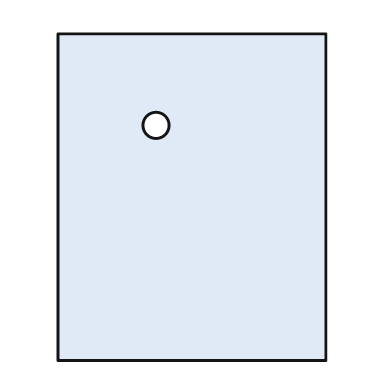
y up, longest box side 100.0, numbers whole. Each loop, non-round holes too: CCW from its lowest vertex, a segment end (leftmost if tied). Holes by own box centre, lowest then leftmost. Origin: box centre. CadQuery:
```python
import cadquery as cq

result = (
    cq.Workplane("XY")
    .moveTo(-41.0, -50.0)
    .lineTo(41.0, -50.0)
    .lineTo(41.0, 50.0)
    .lineTo(-41.0, 50.0)
    .close()
    .moveTo(-11.0, 22.0)
    .circle(4.0)
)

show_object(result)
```